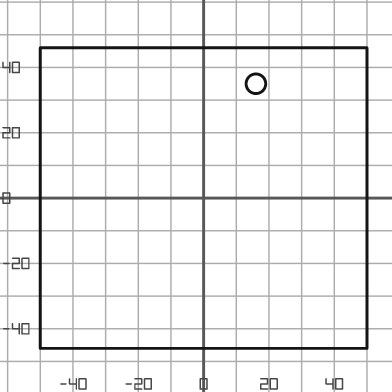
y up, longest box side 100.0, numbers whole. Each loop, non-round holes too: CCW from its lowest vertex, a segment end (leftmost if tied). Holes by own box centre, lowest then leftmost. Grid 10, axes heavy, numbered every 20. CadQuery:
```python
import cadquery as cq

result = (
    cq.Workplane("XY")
    .moveTo(-50.0, -46.0)
    .lineTo(50.0, -46.0)
    .lineTo(50.0, 46.0)
    .lineTo(-50.0, 46.0)
    .close()
    .moveTo(16.0, 35.0)
    .circle(3.0)
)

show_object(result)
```